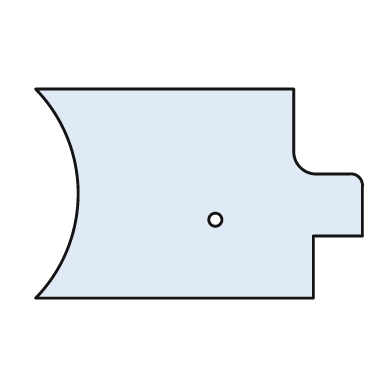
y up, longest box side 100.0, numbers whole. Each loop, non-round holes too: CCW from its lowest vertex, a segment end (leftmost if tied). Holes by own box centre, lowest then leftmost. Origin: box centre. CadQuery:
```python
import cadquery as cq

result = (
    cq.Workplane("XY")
    .moveTo(-50.0, -32.0)
    .lineTo(35.0, -32.0)
    .lineTo(35.0, -13.0)
    .lineTo(50.0, -13.0)
    .lineTo(50.0, 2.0)
    .threePointArc((49.0, 5.0), (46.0, 6.0))
    .lineTo(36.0, 6.0)
    .threePointArc((31.0, 8.0), (29.0, 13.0))
    .lineTo(29.0, 32.0)
    .lineTo(-50.0, 32.0)
    .threePointArc((-37.0, 0.0), (-50.0, -32.0))
    .close()
    .moveTo(5.0, -8.0)
    .circle(2.0)
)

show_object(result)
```